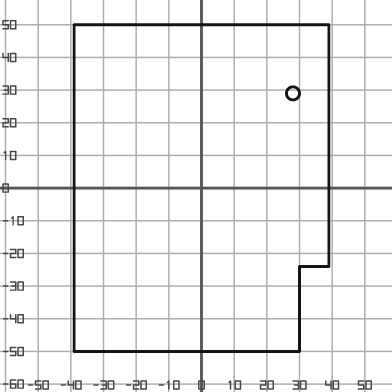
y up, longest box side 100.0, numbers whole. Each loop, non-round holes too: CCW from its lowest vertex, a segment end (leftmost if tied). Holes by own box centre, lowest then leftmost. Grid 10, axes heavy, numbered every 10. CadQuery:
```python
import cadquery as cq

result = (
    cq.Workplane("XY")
    .moveTo(-39.0, -50.0)
    .lineTo(30.0, -50.0)
    .lineTo(30.0, -24.0)
    .lineTo(39.0, -24.0)
    .lineTo(39.0, 50.0)
    .lineTo(-39.0, 50.0)
    .close()
    .moveTo(28.0, 29.0)
    .circle(2.0)
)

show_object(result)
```